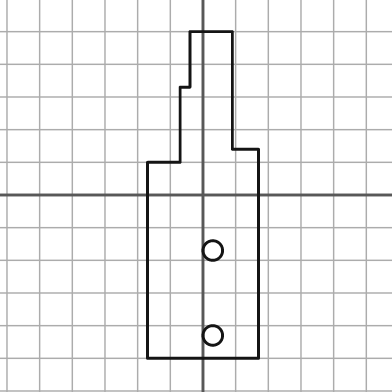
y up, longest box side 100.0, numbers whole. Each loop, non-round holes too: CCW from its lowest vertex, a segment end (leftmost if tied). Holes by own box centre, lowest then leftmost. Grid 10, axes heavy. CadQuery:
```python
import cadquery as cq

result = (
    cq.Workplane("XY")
    .moveTo(-17.0, -50.0)
    .lineTo(17.0, -50.0)
    .lineTo(17.0, 14.0)
    .lineTo(9.0, 14.0)
    .lineTo(9.0, 50.0)
    .lineTo(-4.0, 50.0)
    .lineTo(-4.0, 33.0)
    .lineTo(-7.0, 33.0)
    .lineTo(-7.0, 10.0)
    .lineTo(-17.0, 10.0)
    .close()
    .moveTo(3.0, -43.0)
    .circle(3.0)
    .moveTo(3.0, -17.0)
    .circle(3.0)
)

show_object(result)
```